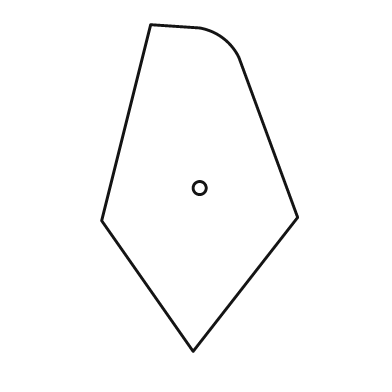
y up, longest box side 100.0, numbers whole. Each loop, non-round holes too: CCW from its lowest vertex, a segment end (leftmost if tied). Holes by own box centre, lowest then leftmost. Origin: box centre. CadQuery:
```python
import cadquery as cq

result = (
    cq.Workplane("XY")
    .moveTo(-2.0, -50.0)
    .lineTo(30.0, -9.0)
    .lineTo(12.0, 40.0)
    .threePointArc((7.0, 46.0), (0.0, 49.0))
    .lineTo(-15.0, 50.0)
    .lineTo(-30.0, -10.0)
    .close()
    .moveTo(0.0, 0.0)
    .circle(2.0)
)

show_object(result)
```